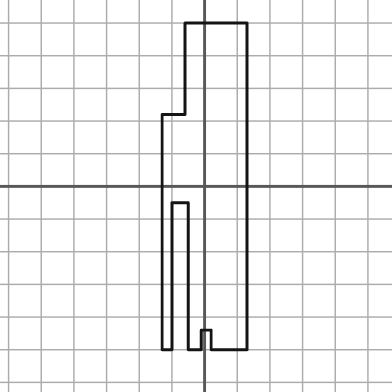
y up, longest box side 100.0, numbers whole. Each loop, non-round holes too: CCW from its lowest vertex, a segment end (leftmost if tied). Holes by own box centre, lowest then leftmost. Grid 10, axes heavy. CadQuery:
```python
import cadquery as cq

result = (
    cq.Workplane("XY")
    .moveTo(-13.0, -50.0)
    .lineTo(-10.0, -50.0)
    .lineTo(-10.0, -5.0)
    .lineTo(-5.0, -5.0)
    .lineTo(-5.0, -50.0)
    .lineTo(-1.0, -50.0)
    .lineTo(-1.0, -44.0)
    .lineTo(2.0, -44.0)
    .lineTo(2.0, -50.0)
    .lineTo(13.0, -50.0)
    .lineTo(13.0, 50.0)
    .lineTo(-6.0, 50.0)
    .lineTo(-6.0, 22.0)
    .lineTo(-13.0, 22.0)
    .close()
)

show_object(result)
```